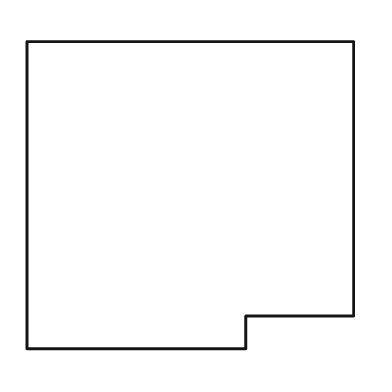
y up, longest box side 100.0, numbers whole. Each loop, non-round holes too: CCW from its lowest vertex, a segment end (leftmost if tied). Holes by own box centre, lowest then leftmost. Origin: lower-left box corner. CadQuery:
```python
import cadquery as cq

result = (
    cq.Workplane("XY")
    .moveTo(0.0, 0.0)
    .lineTo(67.0, 0.0)
    .lineTo(67.0, 10.0)
    .lineTo(100.0, 10.0)
    .lineTo(100.0, 94.0)
    .lineTo(0.0, 94.0)
    .close()
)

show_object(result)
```